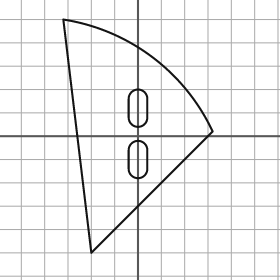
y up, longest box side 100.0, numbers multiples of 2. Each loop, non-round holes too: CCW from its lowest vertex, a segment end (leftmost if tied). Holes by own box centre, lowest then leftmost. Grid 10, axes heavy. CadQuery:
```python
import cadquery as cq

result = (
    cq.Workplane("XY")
    .moveTo(-20.0, -50.0)
    .lineTo(32.0, 2.0)
    .threePointArc((6.0, 34.0), (-32.0, 50.0))
    .close()
    .moveTo(-4.0, -14.0)
    .threePointArc((0.0, -18.0), (4.0, -14.0))
    .lineTo(4.0, -6.0)
    .threePointArc((0.0, -2.0), (-4.0, -6.0))
    .close()
    .moveTo(-4.0, 8.0)
    .threePointArc((0.0, 4.0), (4.0, 8.0))
    .lineTo(4.0, 16.0)
    .threePointArc((0.0, 20.0), (-4.0, 16.0))
    .close()
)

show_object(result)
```